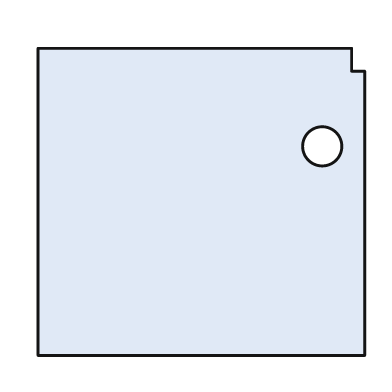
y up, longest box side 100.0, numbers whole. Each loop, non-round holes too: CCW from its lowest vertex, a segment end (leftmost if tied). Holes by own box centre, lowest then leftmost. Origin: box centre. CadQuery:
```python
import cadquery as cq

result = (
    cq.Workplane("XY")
    .moveTo(-50.0, -47.0)
    .lineTo(50.0, -47.0)
    .lineTo(50.0, 40.0)
    .lineTo(46.0, 40.0)
    .lineTo(46.0, 47.0)
    .lineTo(-50.0, 47.0)
    .close()
    .moveTo(37.0, 17.0)
    .circle(6.0)
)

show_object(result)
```